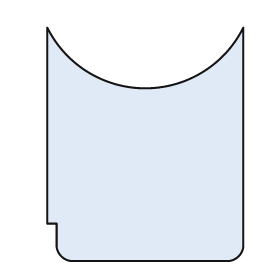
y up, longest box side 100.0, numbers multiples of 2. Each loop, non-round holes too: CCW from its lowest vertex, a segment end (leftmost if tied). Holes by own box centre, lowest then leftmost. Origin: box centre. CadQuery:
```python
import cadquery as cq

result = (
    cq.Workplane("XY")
    .moveTo(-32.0, -50.0)
    .lineTo(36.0, -50.0)
    .threePointArc((40.0, -48.0), (42.0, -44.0))
    .lineTo(42.0, 50.0)
    .threePointArc((0.0, 24.0), (-42.0, 50.0))
    .lineTo(-42.0, -34.0)
    .lineTo(-38.0, -34.0)
    .lineTo(-38.0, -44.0)
    .threePointArc((-36.0, -48.0), (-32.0, -50.0))
    .close()
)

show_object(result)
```